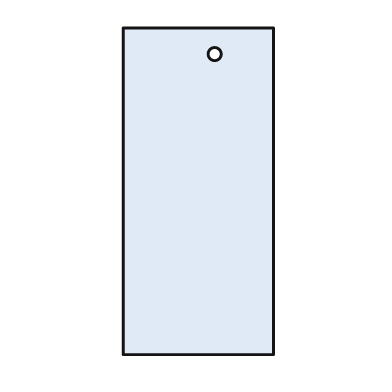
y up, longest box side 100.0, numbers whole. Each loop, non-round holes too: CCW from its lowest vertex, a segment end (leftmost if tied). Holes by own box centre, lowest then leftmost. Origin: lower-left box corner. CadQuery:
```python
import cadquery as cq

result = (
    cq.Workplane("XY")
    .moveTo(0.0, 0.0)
    .lineTo(46.0, 0.0)
    .lineTo(46.0, 100.0)
    .lineTo(0.0, 100.0)
    .close()
    .moveTo(28.0, 92.0)
    .circle(2.0)
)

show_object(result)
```